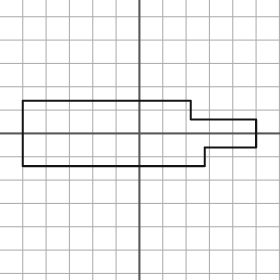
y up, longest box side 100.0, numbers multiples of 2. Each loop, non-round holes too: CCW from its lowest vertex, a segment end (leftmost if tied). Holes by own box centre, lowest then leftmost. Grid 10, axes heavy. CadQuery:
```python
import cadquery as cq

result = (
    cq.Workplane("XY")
    .moveTo(-50.0, -14.0)
    .lineTo(28.0, -14.0)
    .lineTo(28.0, -6.0)
    .lineTo(50.0, -6.0)
    .lineTo(50.0, 6.0)
    .lineTo(22.0, 6.0)
    .lineTo(22.0, 14.0)
    .lineTo(-50.0, 14.0)
    .close()
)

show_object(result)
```